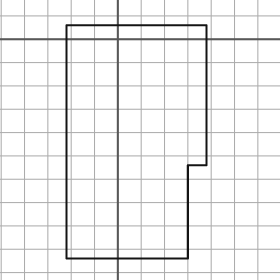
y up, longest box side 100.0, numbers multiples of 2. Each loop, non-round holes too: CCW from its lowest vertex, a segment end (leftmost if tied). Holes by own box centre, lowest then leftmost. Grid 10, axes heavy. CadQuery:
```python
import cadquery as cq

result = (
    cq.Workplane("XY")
    .moveTo(-22.0, -94.0)
    .lineTo(30.0, -94.0)
    .lineTo(30.0, -54.0)
    .lineTo(38.0, -54.0)
    .lineTo(38.0, 6.0)
    .lineTo(-22.0, 6.0)
    .close()
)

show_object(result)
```